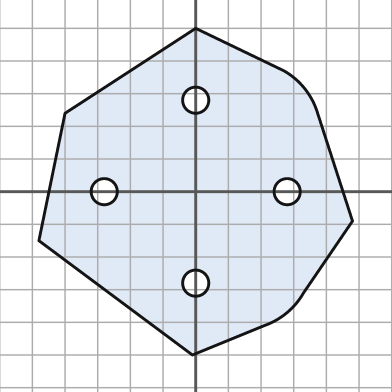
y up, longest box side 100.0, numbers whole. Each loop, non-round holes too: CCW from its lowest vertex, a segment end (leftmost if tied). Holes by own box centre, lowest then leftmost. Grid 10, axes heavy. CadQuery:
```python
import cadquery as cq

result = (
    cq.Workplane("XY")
    .moveTo(-1.0, -50.0)
    .lineTo(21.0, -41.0)
    .threePointArc((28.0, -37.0), (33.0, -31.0))
    .lineTo(48.0, -9.0)
    .lineTo(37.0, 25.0)
    .threePointArc((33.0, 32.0), (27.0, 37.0))
    .lineTo(0.0, 50.0)
    .lineTo(-40.0, 24.0)
    .lineTo(-48.0, -15.0)
    .close()
    .moveTo(0.0, -28.0)
    .circle(4.0)
    .moveTo(-28.0, 0.0)
    .circle(4.0)
    .moveTo(28.0, 0.0)
    .circle(4.0)
    .moveTo(0.0, 28.0)
    .circle(4.0)
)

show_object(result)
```